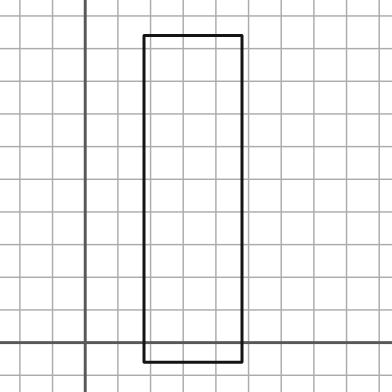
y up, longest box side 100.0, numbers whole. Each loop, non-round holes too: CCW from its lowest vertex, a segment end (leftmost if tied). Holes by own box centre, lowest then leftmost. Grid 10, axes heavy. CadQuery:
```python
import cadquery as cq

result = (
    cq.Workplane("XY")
    .moveTo(18.0, -6.0)
    .lineTo(48.0, -6.0)
    .lineTo(48.0, 94.0)
    .lineTo(18.0, 94.0)
    .close()
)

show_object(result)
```